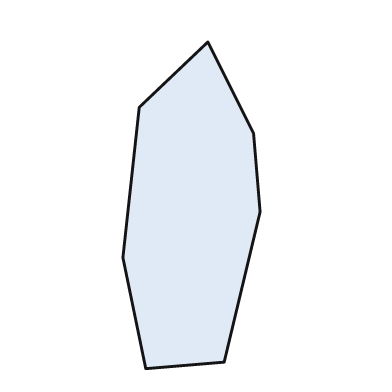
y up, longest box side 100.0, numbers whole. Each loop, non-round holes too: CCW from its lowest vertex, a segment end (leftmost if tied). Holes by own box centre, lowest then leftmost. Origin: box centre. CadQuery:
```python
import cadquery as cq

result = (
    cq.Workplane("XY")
    .moveTo(-14.0, -50.0)
    .lineTo(10.0, -48.0)
    .lineTo(21.0, -2.0)
    .lineTo(19.0, 22.0)
    .lineTo(5.0, 50.0)
    .lineTo(-16.0, 30.0)
    .lineTo(-21.0, -16.0)
    .close()
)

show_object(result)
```